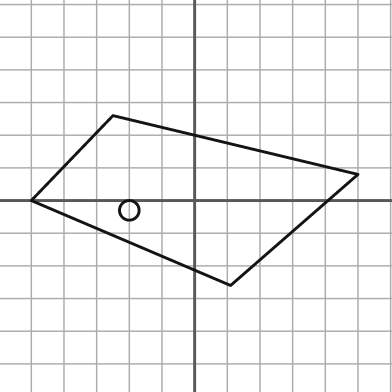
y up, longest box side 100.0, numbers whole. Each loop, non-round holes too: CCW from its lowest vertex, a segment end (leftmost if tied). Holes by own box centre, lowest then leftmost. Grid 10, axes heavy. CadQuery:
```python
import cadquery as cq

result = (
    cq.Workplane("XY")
    .moveTo(11.0, -26.0)
    .lineTo(50.0, 8.0)
    .lineTo(-25.0, 26.0)
    .lineTo(-50.0, 0.0)
    .close()
    .moveTo(-20.0, -3.0)
    .circle(3.0)
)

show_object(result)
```